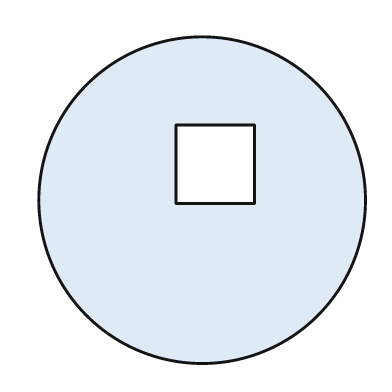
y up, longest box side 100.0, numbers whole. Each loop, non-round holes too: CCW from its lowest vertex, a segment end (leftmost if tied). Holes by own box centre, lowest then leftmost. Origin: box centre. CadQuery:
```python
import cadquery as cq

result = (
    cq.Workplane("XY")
    .moveTo(0.0, 0.0)
    .circle(50.0)
    .moveTo(-8.0, -1.0)
    .lineTo(16.0, -1.0)
    .lineTo(16.0, 23.0)
    .lineTo(-8.0, 23.0)
    .close()
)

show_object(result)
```